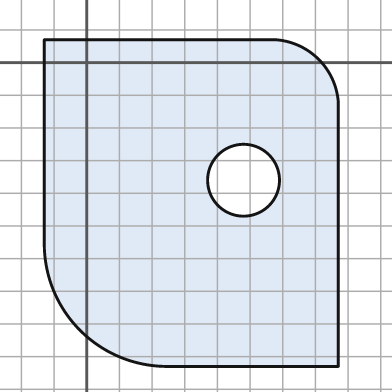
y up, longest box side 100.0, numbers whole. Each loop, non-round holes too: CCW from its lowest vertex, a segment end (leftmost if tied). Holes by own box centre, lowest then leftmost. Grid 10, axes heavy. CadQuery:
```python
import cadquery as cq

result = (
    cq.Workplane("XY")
    .moveTo(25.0, -93.0)
    .lineTo(77.0, -93.0)
    .lineTo(77.0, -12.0)
    .threePointArc((71.0, 1.0), (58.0, 7.0))
    .lineTo(-13.0, 7.0)
    .lineTo(-13.0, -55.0)
    .threePointArc((-2.0, -82.0), (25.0, -93.0))
    .close()
    .moveTo(48.0, -36.0)
    .circle(11.0)
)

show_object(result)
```